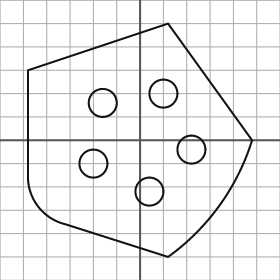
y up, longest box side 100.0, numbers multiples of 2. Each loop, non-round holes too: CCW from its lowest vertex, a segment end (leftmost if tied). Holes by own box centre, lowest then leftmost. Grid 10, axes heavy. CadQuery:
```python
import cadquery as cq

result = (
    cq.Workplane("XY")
    .moveTo(12.0, -50.0)
    .threePointArc((34.0, -28.0), (48.0, 0.0))
    .lineTo(12.0, 50.0)
    .lineTo(-48.0, 30.0)
    .lineTo(-48.0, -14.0)
    .threePointArc((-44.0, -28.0), (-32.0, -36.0))
    .close()
    .moveTo(4.0, -22.0)
    .circle(6.0)
    .moveTo(-20.0, -10.0)
    .circle(6.0)
    .moveTo(22.0, -4.0)
    .circle(6.0)
    .moveTo(-16.0, 16.0)
    .circle(6.0)
    .moveTo(10.0, 20.0)
    .circle(6.0)
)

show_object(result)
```